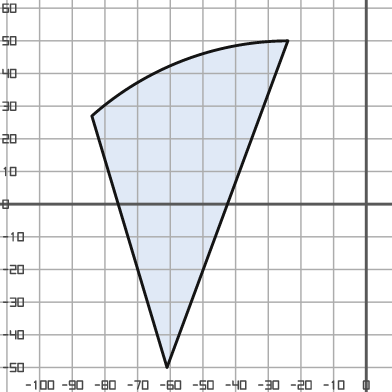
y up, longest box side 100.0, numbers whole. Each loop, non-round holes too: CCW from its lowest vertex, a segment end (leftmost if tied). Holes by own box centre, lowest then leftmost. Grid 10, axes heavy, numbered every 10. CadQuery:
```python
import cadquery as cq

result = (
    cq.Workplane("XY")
    .moveTo(-61.0, -50.0)
    .lineTo(-24.0, 50.0)
    .threePointArc((-56.0, 44.0), (-84.0, 27.0))
    .close()
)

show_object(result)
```